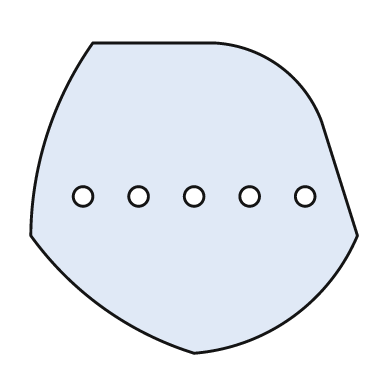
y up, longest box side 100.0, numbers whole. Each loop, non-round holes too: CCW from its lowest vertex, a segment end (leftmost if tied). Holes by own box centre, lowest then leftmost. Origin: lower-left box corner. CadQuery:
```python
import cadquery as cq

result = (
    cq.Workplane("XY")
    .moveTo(50.0, 0.0)
    .threePointArc((80.0, 11.0), (100.0, 36.0))
    .lineTo(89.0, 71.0)
    .threePointArc((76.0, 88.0), (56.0, 95.0))
    .lineTo(19.0, 95.0)
    .threePointArc((5.0, 67.0), (0.0, 36.0))
    .threePointArc((22.0, 14.0), (50.0, 0.0))
    .close()
    .moveTo(16.0, 48.0)
    .circle(3.0)
    .moveTo(33.0, 48.0)
    .circle(3.0)
    .moveTo(50.0, 48.0)
    .circle(3.0)
    .moveTo(67.0, 48.0)
    .circle(3.0)
    .moveTo(84.0, 48.0)
    .circle(3.0)
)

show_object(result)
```